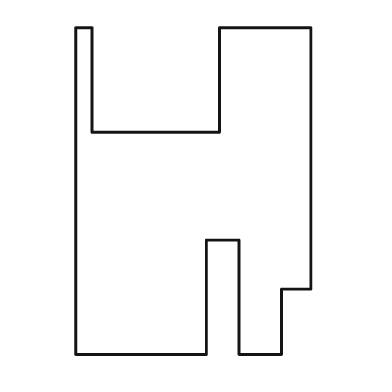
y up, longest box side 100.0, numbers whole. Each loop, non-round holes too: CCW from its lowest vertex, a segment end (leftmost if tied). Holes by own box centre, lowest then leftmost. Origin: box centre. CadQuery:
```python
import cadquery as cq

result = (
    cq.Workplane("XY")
    .moveTo(-36.0, -50.0)
    .lineTo(4.0, -50.0)
    .lineTo(4.0, -15.0)
    .lineTo(14.0, -15.0)
    .lineTo(14.0, -50.0)
    .lineTo(27.0, -50.0)
    .lineTo(27.0, -30.0)
    .lineTo(36.0, -30.0)
    .lineTo(36.0, 50.0)
    .lineTo(8.0, 50.0)
    .lineTo(8.0, 18.0)
    .lineTo(-31.0, 18.0)
    .lineTo(-31.0, 50.0)
    .lineTo(-36.0, 50.0)
    .close()
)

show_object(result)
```